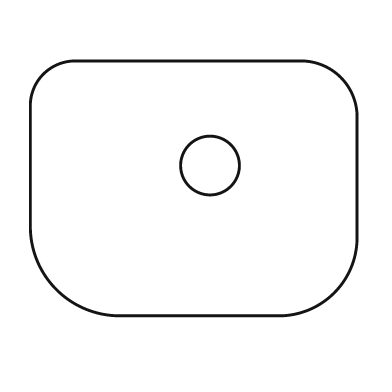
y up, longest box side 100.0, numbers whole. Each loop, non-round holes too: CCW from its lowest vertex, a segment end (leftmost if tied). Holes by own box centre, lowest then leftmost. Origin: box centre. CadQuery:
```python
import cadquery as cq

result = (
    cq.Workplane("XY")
    .moveTo(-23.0, -39.0)
    .lineTo(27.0, -39.0)
    .threePointArc((43.0, -32.0), (50.0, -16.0))
    .lineTo(50.0, 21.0)
    .threePointArc((45.0, 34.0), (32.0, 39.0))
    .lineTo(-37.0, 39.0)
    .threePointArc((-46.0, 35.0), (-50.0, 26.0))
    .lineTo(-50.0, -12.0)
    .threePointArc((-42.0, -31.0), (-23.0, -39.0))
    .close()
    .moveTo(5.0, 7.0)
    .circle(9.0)
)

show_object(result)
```